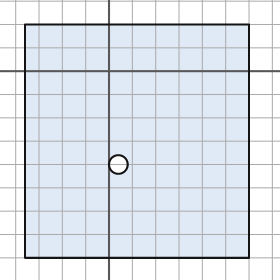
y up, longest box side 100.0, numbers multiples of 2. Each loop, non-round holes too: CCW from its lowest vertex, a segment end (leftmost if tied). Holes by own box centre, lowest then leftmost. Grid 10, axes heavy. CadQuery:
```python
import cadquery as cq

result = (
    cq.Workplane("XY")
    .moveTo(-36.0, -80.0)
    .lineTo(60.0, -80.0)
    .lineTo(60.0, 20.0)
    .lineTo(-36.0, 20.0)
    .close()
    .moveTo(4.0, -40.0)
    .circle(4.0)
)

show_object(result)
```